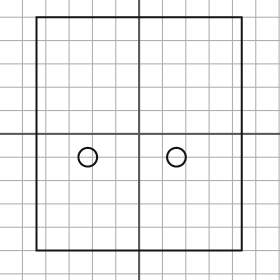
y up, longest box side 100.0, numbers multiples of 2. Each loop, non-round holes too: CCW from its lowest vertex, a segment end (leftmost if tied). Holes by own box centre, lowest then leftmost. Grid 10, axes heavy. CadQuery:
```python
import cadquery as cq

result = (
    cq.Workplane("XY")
    .moveTo(-44.0, -50.0)
    .lineTo(44.0, -50.0)
    .lineTo(44.0, 50.0)
    .lineTo(-44.0, 50.0)
    .close()
    .moveTo(-22.0, -10.0)
    .circle(4.0)
    .moveTo(16.0, -10.0)
    .circle(4.0)
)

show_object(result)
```